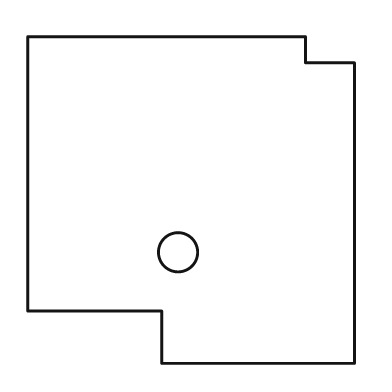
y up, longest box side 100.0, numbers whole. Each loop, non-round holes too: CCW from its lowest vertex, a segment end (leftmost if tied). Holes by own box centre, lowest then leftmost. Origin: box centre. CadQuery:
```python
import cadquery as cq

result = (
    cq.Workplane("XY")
    .moveTo(-9.0, -50.0)
    .lineTo(50.0, -50.0)
    .lineTo(50.0, 42.0)
    .lineTo(35.0, 42.0)
    .lineTo(35.0, 50.0)
    .lineTo(-50.0, 50.0)
    .lineTo(-50.0, -34.0)
    .lineTo(-9.0, -34.0)
    .close()
    .moveTo(-4.0, -16.0)
    .circle(6.0)
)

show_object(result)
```